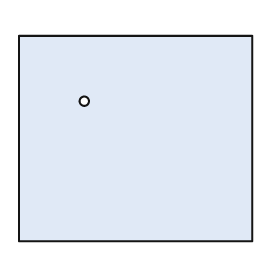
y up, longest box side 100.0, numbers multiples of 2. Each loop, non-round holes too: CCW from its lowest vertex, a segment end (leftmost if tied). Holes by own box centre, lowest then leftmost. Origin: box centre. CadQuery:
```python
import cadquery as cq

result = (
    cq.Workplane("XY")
    .moveTo(-50.0, -44.0)
    .lineTo(50.0, -44.0)
    .lineTo(50.0, 44.0)
    .lineTo(-50.0, 44.0)
    .close()
    .moveTo(-22.0, 16.0)
    .circle(2.0)
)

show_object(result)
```